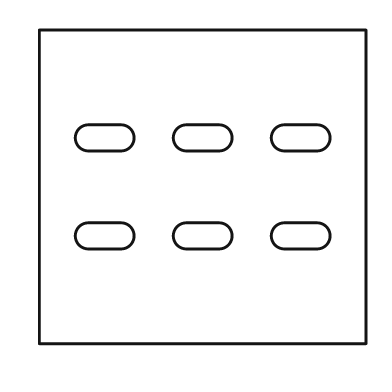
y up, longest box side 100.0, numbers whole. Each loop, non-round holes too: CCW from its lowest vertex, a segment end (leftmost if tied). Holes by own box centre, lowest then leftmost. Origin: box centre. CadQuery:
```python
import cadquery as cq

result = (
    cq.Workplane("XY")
    .moveTo(-50.0, -48.0)
    .lineTo(50.0, -48.0)
    .lineTo(50.0, 48.0)
    .lineTo(-50.0, 48.0)
    .close()
    .moveTo(-35.0, -19.0)
    .lineTo(-25.0, -19.0)
    .threePointArc((-21.0, -15.0), (-25.0, -11.0))
    .lineTo(-35.0, -11.0)
    .threePointArc((-39.0, -15.0), (-35.0, -19.0))
    .close()
    .moveTo(-5.0, -19.0)
    .lineTo(5.0, -19.0)
    .threePointArc((9.0, -15.0), (5.0, -11.0))
    .lineTo(-5.0, -11.0)
    .threePointArc((-9.0, -15.0), (-5.0, -19.0))
    .close()
    .moveTo(25.0, -19.0)
    .lineTo(35.0, -19.0)
    .threePointArc((39.0, -15.0), (35.0, -11.0))
    .lineTo(25.0, -11.0)
    .threePointArc((21.0, -15.0), (25.0, -19.0))
    .close()
    .moveTo(-35.0, 11.0)
    .lineTo(-25.0, 11.0)
    .threePointArc((-21.0, 15.0), (-25.0, 19.0))
    .lineTo(-35.0, 19.0)
    .threePointArc((-39.0, 15.0), (-35.0, 11.0))
    .close()
    .moveTo(-5.0, 11.0)
    .lineTo(5.0, 11.0)
    .threePointArc((9.0, 15.0), (5.0, 19.0))
    .lineTo(-5.0, 19.0)
    .threePointArc((-9.0, 15.0), (-5.0, 11.0))
    .close()
    .moveTo(25.0, 11.0)
    .lineTo(35.0, 11.0)
    .threePointArc((39.0, 15.0), (35.0, 19.0))
    .lineTo(25.0, 19.0)
    .threePointArc((21.0, 15.0), (25.0, 11.0))
    .close()
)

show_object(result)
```